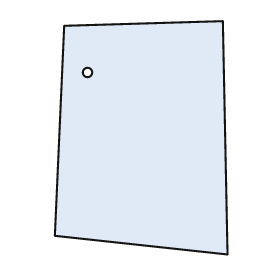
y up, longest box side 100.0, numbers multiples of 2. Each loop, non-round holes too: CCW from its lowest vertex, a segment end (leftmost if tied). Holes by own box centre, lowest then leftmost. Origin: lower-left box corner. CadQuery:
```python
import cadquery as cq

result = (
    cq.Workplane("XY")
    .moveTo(74.0, 0.0)
    .lineTo(72.0, 100.0)
    .lineTo(4.0, 98.0)
    .lineTo(0.0, 8.0)
    .close()
    .moveTo(14.0, 78.0)
    .circle(2.0)
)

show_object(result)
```